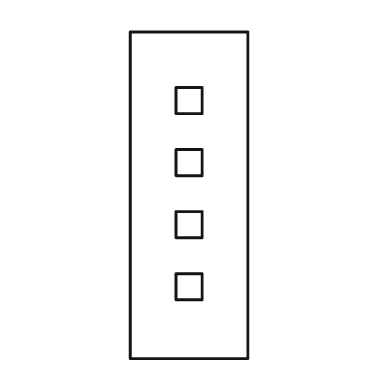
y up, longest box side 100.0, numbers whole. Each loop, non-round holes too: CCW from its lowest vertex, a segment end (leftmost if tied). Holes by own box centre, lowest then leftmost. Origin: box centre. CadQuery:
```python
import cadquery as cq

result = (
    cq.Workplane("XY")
    .moveTo(-18.0, -50.0)
    .lineTo(18.0, -50.0)
    .lineTo(18.0, 50.0)
    .lineTo(-18.0, 50.0)
    .close()
    .moveTo(-4.0, -32.0)
    .lineTo(4.0, -32.0)
    .lineTo(4.0, -24.0)
    .lineTo(-4.0, -24.0)
    .close()
    .moveTo(-4.0, -13.0)
    .lineTo(4.0, -13.0)
    .lineTo(4.0, -5.0)
    .lineTo(-4.0, -5.0)
    .close()
    .moveTo(-4.0, 6.0)
    .lineTo(4.0, 6.0)
    .lineTo(4.0, 14.0)
    .lineTo(-4.0, 14.0)
    .close()
    .moveTo(-4.0, 25.0)
    .lineTo(4.0, 25.0)
    .lineTo(4.0, 33.0)
    .lineTo(-4.0, 33.0)
    .close()
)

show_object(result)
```